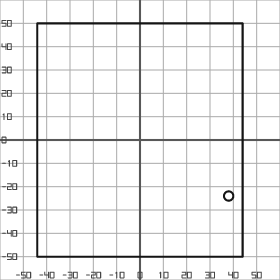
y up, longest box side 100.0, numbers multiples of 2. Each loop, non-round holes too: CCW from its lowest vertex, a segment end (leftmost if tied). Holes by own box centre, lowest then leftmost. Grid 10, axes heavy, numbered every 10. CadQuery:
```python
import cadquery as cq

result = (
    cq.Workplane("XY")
    .moveTo(-44.0, -50.0)
    .lineTo(44.0, -50.0)
    .lineTo(44.0, 50.0)
    .lineTo(-44.0, 50.0)
    .close()
    .moveTo(38.0, -24.0)
    .circle(2.0)
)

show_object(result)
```